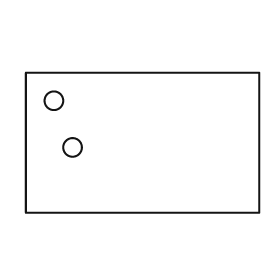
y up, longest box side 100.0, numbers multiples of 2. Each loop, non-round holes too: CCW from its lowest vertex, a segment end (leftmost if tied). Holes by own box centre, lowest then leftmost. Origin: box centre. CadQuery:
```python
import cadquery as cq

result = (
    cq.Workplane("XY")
    .moveTo(-50.0, -30.0)
    .lineTo(50.0, -30.0)
    .lineTo(50.0, 30.0)
    .lineTo(-50.0, 30.0)
    .close()
    .moveTo(-30.0, -2.0)
    .circle(4.0)
    .moveTo(-38.0, 18.0)
    .circle(4.0)
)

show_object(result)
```